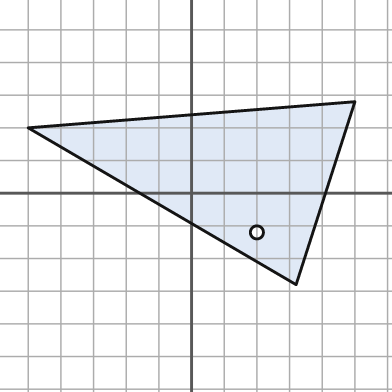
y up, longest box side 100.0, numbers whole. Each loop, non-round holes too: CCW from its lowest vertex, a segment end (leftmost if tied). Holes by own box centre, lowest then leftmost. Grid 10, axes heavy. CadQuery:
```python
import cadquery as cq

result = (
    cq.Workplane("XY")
    .moveTo(32.0, -28.0)
    .lineTo(50.0, 28.0)
    .lineTo(-50.0, 20.0)
    .close()
    .moveTo(20.0, -12.0)
    .circle(2.0)
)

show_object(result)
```